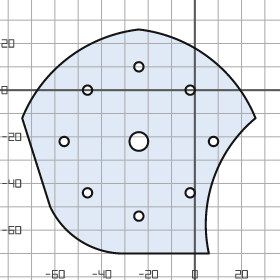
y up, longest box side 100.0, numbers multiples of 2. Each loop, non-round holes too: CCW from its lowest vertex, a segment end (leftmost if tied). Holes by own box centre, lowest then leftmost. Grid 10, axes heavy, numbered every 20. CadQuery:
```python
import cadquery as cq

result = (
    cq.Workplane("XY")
    .moveTo(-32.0, -70.0)
    .lineTo(6.0, -70.0)
    .threePointArc((8.0, -38.0), (26.0, -12.0))
    .threePointArc((6.0, 14.0), (-24.0, 26.0))
    .threePointArc((-54.0, 14.0), (-74.0, -12.0))
    .lineTo(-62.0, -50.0)
    .threePointArc((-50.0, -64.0), (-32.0, -70.0))
    .close()
    .moveTo(-24.0, -54.0)
    .circle(2.0)
    .moveTo(-46.0, -44.0)
    .circle(2.0)
    .moveTo(-2.0, -44.0)
    .circle(2.0)
    .moveTo(-56.0, -22.0)
    .circle(2.0)
    .moveTo(-24.0, -22.0)
    .circle(4.0)
    .moveTo(8.0, -22.0)
    .circle(2.0)
    .moveTo(-46.0, 0.0)
    .circle(2.0)
    .moveTo(-2.0, 0.0)
    .circle(2.0)
    .moveTo(-24.0, 10.0)
    .circle(2.0)
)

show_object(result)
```